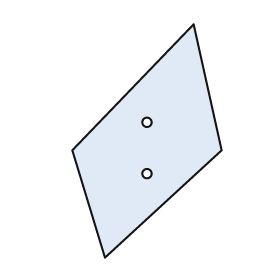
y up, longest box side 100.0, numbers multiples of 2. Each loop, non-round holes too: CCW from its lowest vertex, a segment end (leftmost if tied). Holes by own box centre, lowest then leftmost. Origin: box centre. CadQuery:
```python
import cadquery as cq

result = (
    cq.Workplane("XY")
    .moveTo(-18.0, -50.0)
    .lineTo(32.0, -4.0)
    .lineTo(20.0, 50.0)
    .lineTo(-32.0, -4.0)
    .close()
    .moveTo(0.0, -14.0)
    .circle(2.0)
    .moveTo(0.0, 8.0)
    .circle(2.0)
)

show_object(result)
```